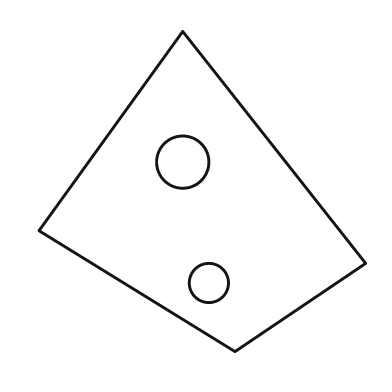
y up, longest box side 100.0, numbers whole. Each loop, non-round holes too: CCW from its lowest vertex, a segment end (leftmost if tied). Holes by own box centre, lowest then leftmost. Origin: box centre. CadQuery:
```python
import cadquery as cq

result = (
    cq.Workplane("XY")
    .moveTo(10.0, -49.0)
    .lineTo(50.0, -22.0)
    .lineTo(-6.0, 49.0)
    .lineTo(-50.0, -12.0)
    .close()
    .moveTo(2.0, -28.0)
    .circle(6.0)
    .moveTo(-6.0, 9.0)
    .circle(8.0)
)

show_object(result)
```